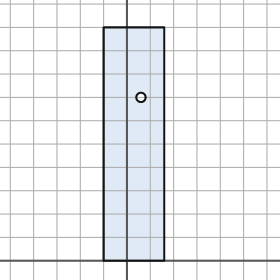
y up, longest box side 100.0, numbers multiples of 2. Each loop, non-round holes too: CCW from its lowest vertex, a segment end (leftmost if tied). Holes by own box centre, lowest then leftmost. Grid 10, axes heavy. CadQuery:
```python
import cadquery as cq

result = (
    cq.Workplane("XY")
    .moveTo(-10.0, 0.0)
    .lineTo(16.0, 0.0)
    .lineTo(16.0, 100.0)
    .lineTo(-10.0, 100.0)
    .close()
    .moveTo(6.0, 70.0)
    .circle(2.0)
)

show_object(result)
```